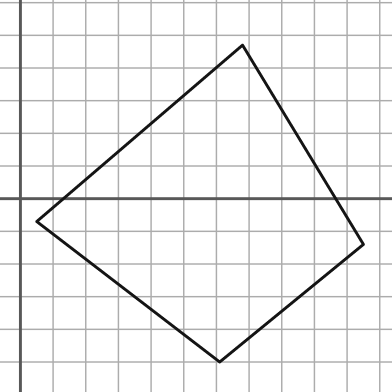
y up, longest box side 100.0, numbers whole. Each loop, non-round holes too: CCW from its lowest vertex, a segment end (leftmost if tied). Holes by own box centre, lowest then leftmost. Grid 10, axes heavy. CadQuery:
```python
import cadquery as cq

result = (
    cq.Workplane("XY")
    .moveTo(61.0, -50.0)
    .lineTo(105.0, -14.0)
    .lineTo(68.0, 47.0)
    .lineTo(5.0, -7.0)
    .close()
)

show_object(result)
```